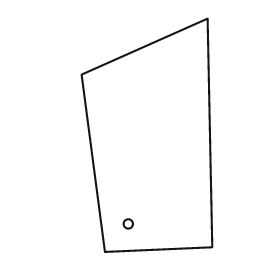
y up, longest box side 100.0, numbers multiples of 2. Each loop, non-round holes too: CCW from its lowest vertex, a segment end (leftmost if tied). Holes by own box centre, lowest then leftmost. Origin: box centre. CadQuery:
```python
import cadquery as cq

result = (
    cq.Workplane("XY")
    .moveTo(-18.0, -50.0)
    .lineTo(28.0, -48.0)
    .lineTo(26.0, 50.0)
    .lineTo(-28.0, 26.0)
    .close()
    .moveTo(-8.0, -38.0)
    .circle(2.0)
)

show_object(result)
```